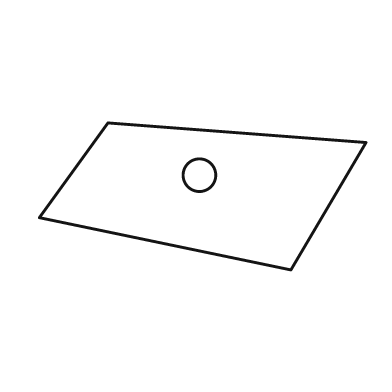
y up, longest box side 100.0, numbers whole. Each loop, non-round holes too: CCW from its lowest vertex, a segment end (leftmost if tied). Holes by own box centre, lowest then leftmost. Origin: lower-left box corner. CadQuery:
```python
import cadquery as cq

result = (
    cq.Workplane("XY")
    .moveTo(77.0, 0.0)
    .lineTo(100.0, 39.0)
    .lineTo(21.0, 45.0)
    .lineTo(0.0, 16.0)
    .close()
    .moveTo(49.0, 29.0)
    .circle(5.0)
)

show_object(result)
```